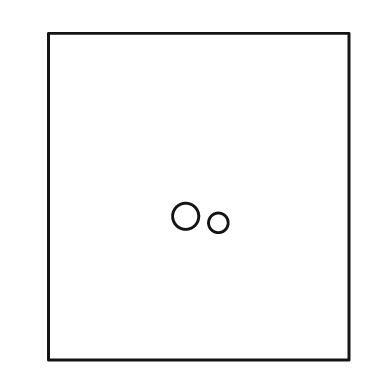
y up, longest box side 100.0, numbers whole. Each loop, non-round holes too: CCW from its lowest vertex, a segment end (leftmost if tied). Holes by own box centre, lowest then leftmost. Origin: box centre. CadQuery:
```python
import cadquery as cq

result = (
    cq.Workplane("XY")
    .moveTo(-46.0, -50.0)
    .lineTo(46.0, -50.0)
    .lineTo(46.0, 50.0)
    .lineTo(-46.0, 50.0)
    .close()
    .moveTo(6.0, -8.0)
    .circle(3.0)
    .moveTo(-4.0, -6.0)
    .circle(4.0)
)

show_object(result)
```